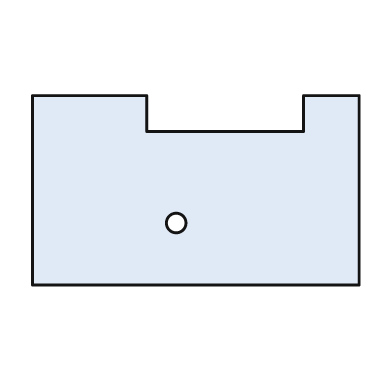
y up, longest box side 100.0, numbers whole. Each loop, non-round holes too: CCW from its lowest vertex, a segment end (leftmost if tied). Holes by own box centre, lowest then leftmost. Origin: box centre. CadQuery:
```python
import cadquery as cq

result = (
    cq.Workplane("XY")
    .moveTo(-50.0, -29.0)
    .lineTo(50.0, -29.0)
    .lineTo(50.0, 29.0)
    .lineTo(33.0, 29.0)
    .lineTo(33.0, 18.0)
    .lineTo(-15.0, 18.0)
    .lineTo(-15.0, 29.0)
    .lineTo(-50.0, 29.0)
    .close()
    .moveTo(-6.0, -10.0)
    .circle(3.0)
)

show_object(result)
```